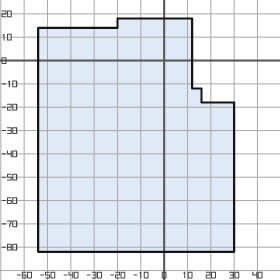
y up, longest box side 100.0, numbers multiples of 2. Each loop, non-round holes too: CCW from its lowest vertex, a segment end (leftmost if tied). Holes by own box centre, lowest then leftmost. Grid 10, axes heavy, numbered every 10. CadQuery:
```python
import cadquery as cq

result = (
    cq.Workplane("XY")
    .moveTo(-54.0, -82.0)
    .lineTo(30.0, -82.0)
    .lineTo(30.0, -18.0)
    .lineTo(16.0, -18.0)
    .lineTo(16.0, -12.0)
    .lineTo(12.0, -12.0)
    .lineTo(12.0, 18.0)
    .lineTo(-20.0, 18.0)
    .lineTo(-20.0, 14.0)
    .lineTo(-54.0, 14.0)
    .close()
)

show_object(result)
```